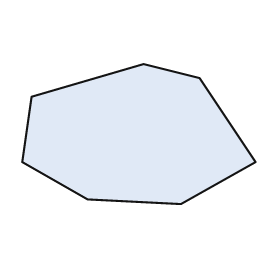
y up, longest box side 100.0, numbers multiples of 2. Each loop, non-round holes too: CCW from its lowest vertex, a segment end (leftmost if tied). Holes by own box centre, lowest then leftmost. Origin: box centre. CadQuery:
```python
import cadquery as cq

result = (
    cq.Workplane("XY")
    .moveTo(18.0, -30.0)
    .lineTo(50.0, -12.0)
    .lineTo(26.0, 24.0)
    .lineTo(2.0, 30.0)
    .lineTo(-46.0, 16.0)
    .lineTo(-50.0, -12.0)
    .lineTo(-22.0, -28.0)
    .close()
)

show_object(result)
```